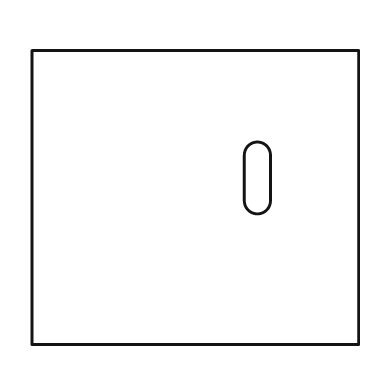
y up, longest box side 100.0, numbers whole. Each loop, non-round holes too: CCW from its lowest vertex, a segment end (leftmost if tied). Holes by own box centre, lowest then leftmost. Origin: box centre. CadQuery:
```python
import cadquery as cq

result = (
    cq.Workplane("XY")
    .moveTo(-50.0, -45.0)
    .lineTo(50.0, -45.0)
    .lineTo(50.0, 45.0)
    .lineTo(-50.0, 45.0)
    .close()
    .moveTo(15.0, -1.0)
    .threePointArc((19.0, -5.0), (23.0, -1.0))
    .lineTo(23.0, 13.0)
    .threePointArc((19.0, 17.0), (15.0, 13.0))
    .close()
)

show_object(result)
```